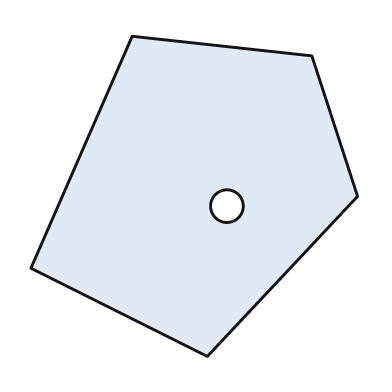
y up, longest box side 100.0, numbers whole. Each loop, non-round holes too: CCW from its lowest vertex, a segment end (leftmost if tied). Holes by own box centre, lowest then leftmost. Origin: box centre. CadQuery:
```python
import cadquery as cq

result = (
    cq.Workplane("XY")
    .moveTo(4.0, -49.0)
    .lineTo(50.0, 0.0)
    .lineTo(36.0, 43.0)
    .lineTo(-19.0, 49.0)
    .lineTo(-50.0, -22.0)
    .close()
    .moveTo(10.0, -3.0)
    .circle(5.0)
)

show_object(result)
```